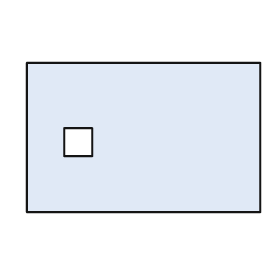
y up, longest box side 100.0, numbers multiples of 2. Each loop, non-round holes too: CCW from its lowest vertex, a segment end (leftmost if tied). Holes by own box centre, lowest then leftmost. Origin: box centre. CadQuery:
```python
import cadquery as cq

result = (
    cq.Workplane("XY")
    .moveTo(-50.0, -32.0)
    .lineTo(50.0, -32.0)
    .lineTo(50.0, 32.0)
    .lineTo(-50.0, 32.0)
    .close()
    .moveTo(-34.0, -8.0)
    .lineTo(-22.0, -8.0)
    .lineTo(-22.0, 4.0)
    .lineTo(-34.0, 4.0)
    .close()
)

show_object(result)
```